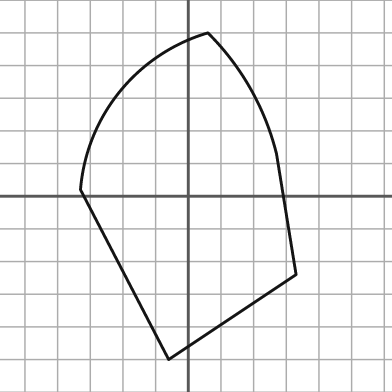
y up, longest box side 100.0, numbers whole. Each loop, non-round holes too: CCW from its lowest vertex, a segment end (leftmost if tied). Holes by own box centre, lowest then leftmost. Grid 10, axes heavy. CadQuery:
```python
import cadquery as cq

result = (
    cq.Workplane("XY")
    .moveTo(-6.0, -50.0)
    .lineTo(33.0, -24.0)
    .lineTo(27.0, 13.0)
    .threePointArc((19.0, 33.0), (6.0, 50.0))
    .threePointArc((-21.0, 32.0), (-33.0, 2.0))
    .close()
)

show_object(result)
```